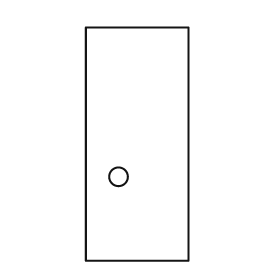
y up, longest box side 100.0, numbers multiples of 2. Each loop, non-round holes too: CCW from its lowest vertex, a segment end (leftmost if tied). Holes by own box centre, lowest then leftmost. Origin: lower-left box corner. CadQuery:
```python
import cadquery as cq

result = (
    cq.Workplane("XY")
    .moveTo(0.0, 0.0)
    .lineTo(44.0, 0.0)
    .lineTo(44.0, 100.0)
    .lineTo(0.0, 100.0)
    .close()
    .moveTo(14.0, 36.0)
    .circle(4.0)
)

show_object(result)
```